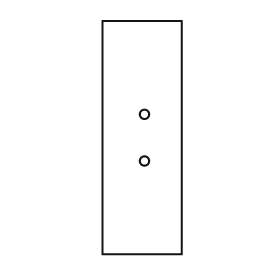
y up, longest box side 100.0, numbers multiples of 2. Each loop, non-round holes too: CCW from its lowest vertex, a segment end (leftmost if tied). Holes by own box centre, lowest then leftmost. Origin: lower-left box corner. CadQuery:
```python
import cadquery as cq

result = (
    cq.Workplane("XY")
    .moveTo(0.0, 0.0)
    .lineTo(34.0, 0.0)
    .lineTo(34.0, 100.0)
    .lineTo(0.0, 100.0)
    .close()
    .moveTo(18.0, 40.0)
    .circle(2.0)
    .moveTo(18.0, 60.0)
    .circle(2.0)
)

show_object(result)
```